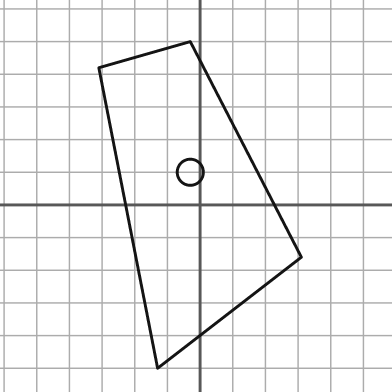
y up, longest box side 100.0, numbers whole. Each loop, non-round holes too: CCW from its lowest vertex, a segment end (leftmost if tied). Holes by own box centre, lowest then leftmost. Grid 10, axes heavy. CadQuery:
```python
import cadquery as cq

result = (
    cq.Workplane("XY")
    .moveTo(-13.0, -50.0)
    .lineTo(31.0, -16.0)
    .lineTo(-3.0, 50.0)
    .lineTo(-31.0, 42.0)
    .close()
    .moveTo(-3.0, 10.0)
    .circle(4.0)
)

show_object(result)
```